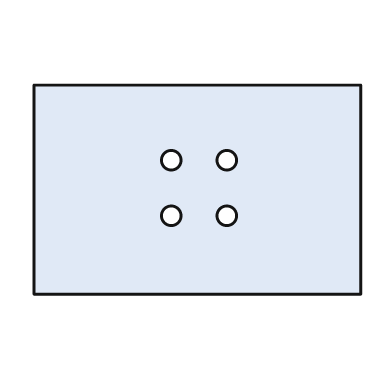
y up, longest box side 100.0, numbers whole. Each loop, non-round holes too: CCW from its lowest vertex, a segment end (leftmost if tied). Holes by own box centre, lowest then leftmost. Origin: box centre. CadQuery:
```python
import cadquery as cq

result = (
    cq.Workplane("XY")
    .moveTo(-50.0, -32.0)
    .lineTo(50.0, -32.0)
    .lineTo(50.0, 32.0)
    .lineTo(-50.0, 32.0)
    .close()
    .moveTo(-8.0, -8.0)
    .circle(3.0)
    .moveTo(9.0, -8.0)
    .circle(3.0)
    .moveTo(-8.0, 9.0)
    .circle(3.0)
    .moveTo(9.0, 9.0)
    .circle(3.0)
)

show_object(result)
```